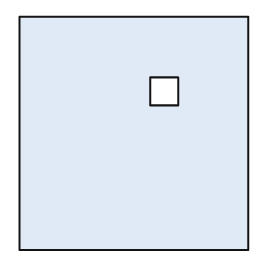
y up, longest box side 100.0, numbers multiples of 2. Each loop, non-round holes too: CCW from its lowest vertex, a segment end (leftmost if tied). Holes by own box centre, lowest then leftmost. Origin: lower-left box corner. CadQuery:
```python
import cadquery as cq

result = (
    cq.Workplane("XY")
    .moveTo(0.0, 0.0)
    .lineTo(98.0, 0.0)
    .lineTo(98.0, 100.0)
    .lineTo(0.0, 100.0)
    .close()
    .moveTo(56.0, 62.0)
    .lineTo(68.0, 62.0)
    .lineTo(68.0, 74.0)
    .lineTo(56.0, 74.0)
    .close()
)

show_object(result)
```